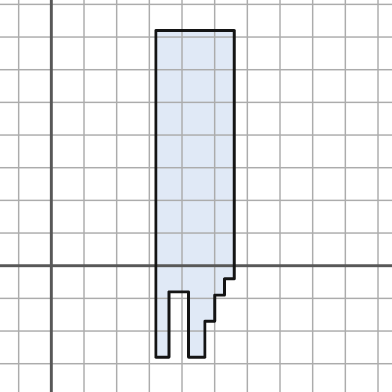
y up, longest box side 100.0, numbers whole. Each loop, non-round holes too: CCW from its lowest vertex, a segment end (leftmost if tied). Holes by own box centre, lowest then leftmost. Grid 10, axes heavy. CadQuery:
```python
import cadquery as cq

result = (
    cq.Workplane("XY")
    .moveTo(32.0, -28.0)
    .lineTo(36.0, -28.0)
    .lineTo(36.0, -8.0)
    .lineTo(42.0, -8.0)
    .lineTo(42.0, -28.0)
    .lineTo(47.0, -28.0)
    .lineTo(47.0, -17.0)
    .lineTo(50.0, -17.0)
    .lineTo(50.0, -9.0)
    .lineTo(53.0, -9.0)
    .lineTo(53.0, -4.0)
    .lineTo(56.0, -4.0)
    .lineTo(56.0, 72.0)
    .lineTo(32.0, 72.0)
    .close()
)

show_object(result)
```